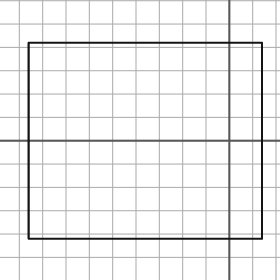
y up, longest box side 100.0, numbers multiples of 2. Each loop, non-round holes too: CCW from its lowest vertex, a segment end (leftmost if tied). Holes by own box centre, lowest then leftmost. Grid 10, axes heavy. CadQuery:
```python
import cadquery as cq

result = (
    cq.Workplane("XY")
    .moveTo(-86.0, -42.0)
    .lineTo(14.0, -42.0)
    .lineTo(14.0, 42.0)
    .lineTo(-86.0, 42.0)
    .close()
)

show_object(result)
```